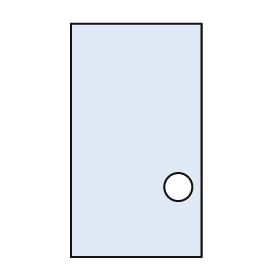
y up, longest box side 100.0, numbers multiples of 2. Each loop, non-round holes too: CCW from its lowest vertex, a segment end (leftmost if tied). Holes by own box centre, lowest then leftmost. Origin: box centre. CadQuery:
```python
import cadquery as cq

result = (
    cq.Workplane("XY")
    .moveTo(-28.0, -50.0)
    .lineTo(28.0, -50.0)
    .lineTo(28.0, 50.0)
    .lineTo(-28.0, 50.0)
    .close()
    .moveTo(18.0, -20.0)
    .circle(6.0)
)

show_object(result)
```